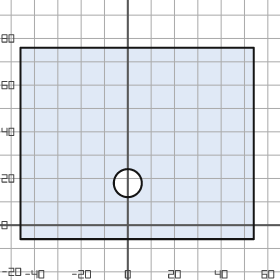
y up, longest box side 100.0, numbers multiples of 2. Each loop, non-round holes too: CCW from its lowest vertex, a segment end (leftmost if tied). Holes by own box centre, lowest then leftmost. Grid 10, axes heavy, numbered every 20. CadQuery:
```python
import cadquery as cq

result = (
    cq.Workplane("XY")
    .moveTo(-46.0, -6.0)
    .lineTo(54.0, -6.0)
    .lineTo(54.0, 76.0)
    .lineTo(-46.0, 76.0)
    .close()
    .moveTo(0.0, 18.0)
    .circle(6.0)
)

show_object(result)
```